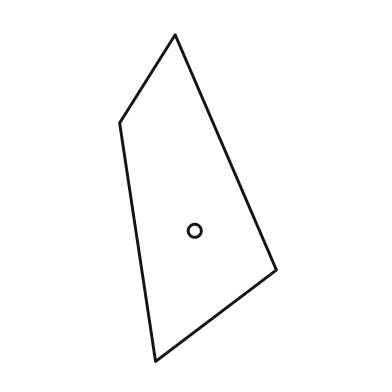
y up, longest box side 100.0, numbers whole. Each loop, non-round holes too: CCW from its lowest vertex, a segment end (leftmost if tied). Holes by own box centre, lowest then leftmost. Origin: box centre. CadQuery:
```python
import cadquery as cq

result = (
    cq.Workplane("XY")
    .moveTo(-13.0, -50.0)
    .lineTo(24.0, -22.0)
    .lineTo(-7.0, 50.0)
    .lineTo(-24.0, 23.0)
    .close()
    .moveTo(-1.0, -10.0)
    .circle(2.0)
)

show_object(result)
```